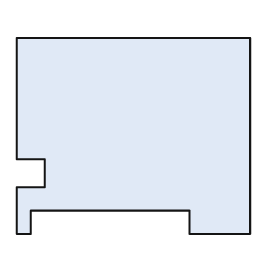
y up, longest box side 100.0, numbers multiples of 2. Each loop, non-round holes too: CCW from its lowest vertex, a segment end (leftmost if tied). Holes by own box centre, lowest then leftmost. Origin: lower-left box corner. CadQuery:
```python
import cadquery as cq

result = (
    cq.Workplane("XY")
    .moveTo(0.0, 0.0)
    .lineTo(6.0, 0.0)
    .lineTo(6.0, 10.0)
    .lineTo(74.0, 10.0)
    .lineTo(74.0, 0.0)
    .lineTo(100.0, 0.0)
    .lineTo(100.0, 84.0)
    .lineTo(0.0, 84.0)
    .lineTo(0.0, 32.0)
    .lineTo(12.0, 32.0)
    .lineTo(12.0, 20.0)
    .lineTo(0.0, 20.0)
    .close()
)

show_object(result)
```